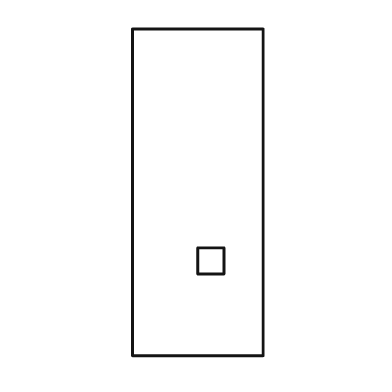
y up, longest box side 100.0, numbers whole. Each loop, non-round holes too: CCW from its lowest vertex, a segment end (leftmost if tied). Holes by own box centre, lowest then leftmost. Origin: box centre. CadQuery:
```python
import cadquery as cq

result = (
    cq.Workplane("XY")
    .moveTo(-20.0, -50.0)
    .lineTo(20.0, -50.0)
    .lineTo(20.0, 50.0)
    .lineTo(-20.0, 50.0)
    .close()
    .moveTo(0.0, -25.0)
    .lineTo(8.0, -25.0)
    .lineTo(8.0, -17.0)
    .lineTo(0.0, -17.0)
    .close()
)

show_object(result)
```